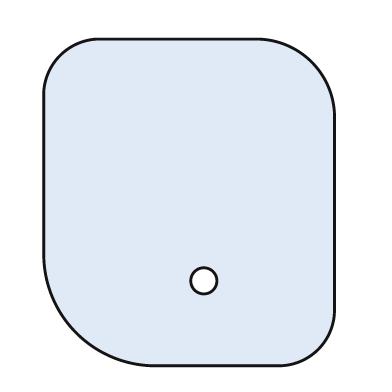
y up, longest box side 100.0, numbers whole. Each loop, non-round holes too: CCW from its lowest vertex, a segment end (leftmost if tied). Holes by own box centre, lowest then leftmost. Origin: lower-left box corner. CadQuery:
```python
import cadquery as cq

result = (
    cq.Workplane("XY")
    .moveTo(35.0, 0.0)
    .lineTo(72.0, 0.0)
    .threePointArc((84.0, 5.0), (89.0, 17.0))
    .lineTo(89.0, 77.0)
    .threePointArc((82.0, 93.0), (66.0, 100.0))
    .lineTo(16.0, 100.0)
    .threePointArc((5.0, 95.0), (0.0, 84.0))
    .lineTo(0.0, 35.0)
    .threePointArc((10.0, 10.0), (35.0, 0.0))
    .close()
    .moveTo(49.0, 26.0)
    .circle(4.0)
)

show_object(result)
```